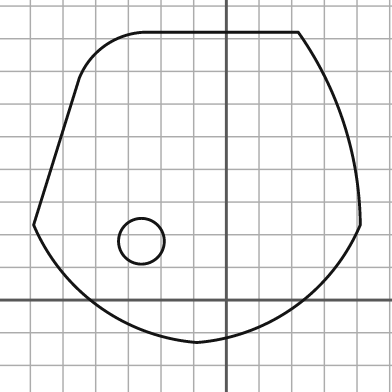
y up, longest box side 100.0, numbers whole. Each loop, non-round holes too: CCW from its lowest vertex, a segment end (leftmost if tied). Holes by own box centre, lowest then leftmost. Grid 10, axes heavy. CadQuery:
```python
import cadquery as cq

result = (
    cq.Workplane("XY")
    .moveTo(-9.0, -13.0)
    .threePointArc((21.0, -2.0), (41.0, 23.0))
    .threePointArc((36.0, 54.0), (22.0, 82.0))
    .lineTo(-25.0, 82.0)
    .threePointArc((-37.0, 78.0), (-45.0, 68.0))
    .lineTo(-59.0, 23.0)
    .threePointArc((-39.0, -2.0), (-9.0, -13.0))
    .close()
    .moveTo(-26.0, 18.0)
    .circle(7.0)
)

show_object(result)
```